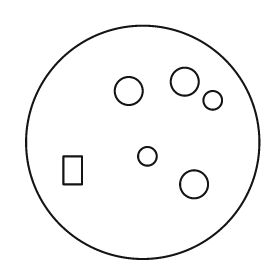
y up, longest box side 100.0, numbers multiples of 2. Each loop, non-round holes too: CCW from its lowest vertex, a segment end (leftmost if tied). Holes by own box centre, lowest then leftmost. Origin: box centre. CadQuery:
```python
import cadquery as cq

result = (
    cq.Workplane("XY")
    .moveTo(0.0, 0.0)
    .circle(50.0)
    .moveTo(22.0, -18.0)
    .circle(6.0)
    .moveTo(-34.0, -18.0)
    .lineTo(-26.0, -18.0)
    .lineTo(-26.0, -6.0)
    .lineTo(-34.0, -6.0)
    .close()
    .moveTo(2.0, -6.0)
    .circle(4.0)
    .moveTo(30.0, 18.0)
    .circle(4.0)
    .moveTo(-6.0, 22.0)
    .circle(6.0)
    .moveTo(18.0, 26.0)
    .circle(6.0)
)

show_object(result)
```